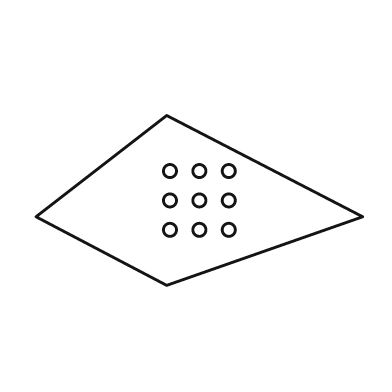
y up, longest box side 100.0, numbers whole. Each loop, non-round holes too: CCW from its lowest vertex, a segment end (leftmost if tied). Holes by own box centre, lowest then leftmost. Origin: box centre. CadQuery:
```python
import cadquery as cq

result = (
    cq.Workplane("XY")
    .moveTo(-10.0, -26.0)
    .lineTo(50.0, -5.0)
    .lineTo(-10.0, 26.0)
    .lineTo(-50.0, -5.0)
    .close()
    .moveTo(-9.0, -9.0)
    .circle(2.0)
    .moveTo(0.0, -9.0)
    .circle(2.0)
    .moveTo(9.0, -9.0)
    .circle(2.0)
    .moveTo(-9.0, 0.0)
    .circle(2.0)
    .moveTo(0.0, 0.0)
    .circle(2.0)
    .moveTo(9.0, 0.0)
    .circle(2.0)
    .moveTo(-9.0, 9.0)
    .circle(2.0)
    .moveTo(0.0, 9.0)
    .circle(2.0)
    .moveTo(9.0, 9.0)
    .circle(2.0)
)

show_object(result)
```